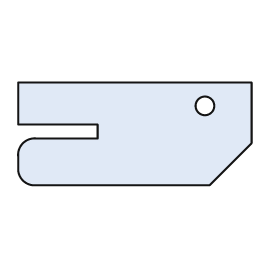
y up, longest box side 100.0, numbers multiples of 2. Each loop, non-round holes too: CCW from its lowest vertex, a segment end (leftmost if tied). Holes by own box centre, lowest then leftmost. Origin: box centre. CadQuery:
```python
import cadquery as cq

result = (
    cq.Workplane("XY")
    .moveTo(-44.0, -22.0)
    .lineTo(32.0, -22.0)
    .lineTo(50.0, -4.0)
    .lineTo(50.0, 22.0)
    .lineTo(-50.0, 22.0)
    .lineTo(-50.0, 4.0)
    .lineTo(-16.0, 4.0)
    .lineTo(-16.0, -2.0)
    .lineTo(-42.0, -2.0)
    .threePointArc((-48.0, -4.0), (-50.0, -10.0))
    .lineTo(-50.0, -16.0)
    .threePointArc((-48.0, -20.0), (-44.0, -22.0))
    .close()
    .moveTo(30.0, 12.0)
    .circle(4.0)
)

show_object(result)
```